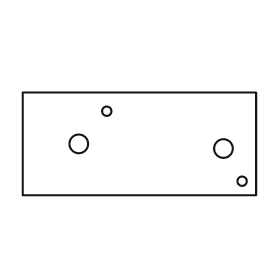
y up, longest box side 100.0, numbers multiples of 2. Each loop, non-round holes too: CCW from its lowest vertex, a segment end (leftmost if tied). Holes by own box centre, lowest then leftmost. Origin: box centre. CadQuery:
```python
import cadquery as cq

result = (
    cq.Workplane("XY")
    .moveTo(-50.0, -22.0)
    .lineTo(50.0, -22.0)
    .lineTo(50.0, 22.0)
    .lineTo(-50.0, 22.0)
    .close()
    .moveTo(44.0, -16.0)
    .circle(2.0)
    .moveTo(36.0, -2.0)
    .circle(4.0)
    .moveTo(-26.0, 0.0)
    .circle(4.0)
    .moveTo(-14.0, 14.0)
    .circle(2.0)
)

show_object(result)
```